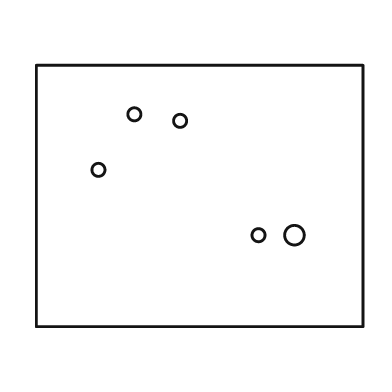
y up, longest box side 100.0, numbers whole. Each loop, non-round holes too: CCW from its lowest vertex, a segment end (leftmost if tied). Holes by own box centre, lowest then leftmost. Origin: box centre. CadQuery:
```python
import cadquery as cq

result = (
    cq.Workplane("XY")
    .moveTo(-50.0, -40.0)
    .lineTo(50.0, -40.0)
    .lineTo(50.0, 40.0)
    .lineTo(-50.0, 40.0)
    .close()
    .moveTo(18.0, -12.0)
    .circle(2.0)
    .moveTo(29.0, -12.0)
    .circle(3.0)
    .moveTo(-31.0, 8.0)
    .circle(2.0)
    .moveTo(-6.0, 23.0)
    .circle(2.0)
    .moveTo(-20.0, 25.0)
    .circle(2.0)
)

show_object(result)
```